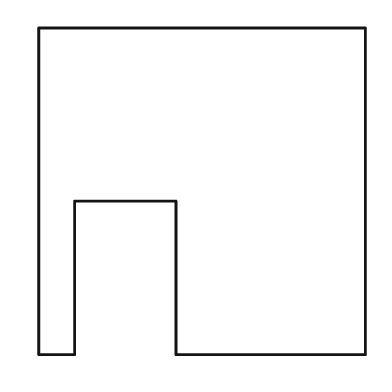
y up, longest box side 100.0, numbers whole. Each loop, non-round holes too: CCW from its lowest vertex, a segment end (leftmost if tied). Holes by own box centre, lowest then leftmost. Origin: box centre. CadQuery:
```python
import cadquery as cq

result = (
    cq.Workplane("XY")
    .moveTo(-50.0, -50.0)
    .lineTo(-39.0, -50.0)
    .lineTo(-39.0, -3.0)
    .lineTo(-8.0, -3.0)
    .lineTo(-8.0, -50.0)
    .lineTo(50.0, -50.0)
    .lineTo(50.0, 50.0)
    .lineTo(-50.0, 50.0)
    .close()
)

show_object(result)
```